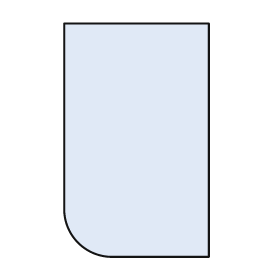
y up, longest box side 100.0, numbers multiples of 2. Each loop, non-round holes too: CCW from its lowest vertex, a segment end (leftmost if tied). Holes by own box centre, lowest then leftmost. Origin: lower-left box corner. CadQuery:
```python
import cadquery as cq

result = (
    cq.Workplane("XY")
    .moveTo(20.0, 0.0)
    .lineTo(62.0, 0.0)
    .lineTo(62.0, 100.0)
    .lineTo(0.0, 100.0)
    .lineTo(0.0, 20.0)
    .threePointArc((6.0, 6.0), (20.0, 0.0))
    .close()
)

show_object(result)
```